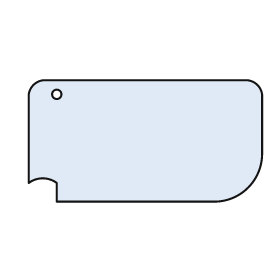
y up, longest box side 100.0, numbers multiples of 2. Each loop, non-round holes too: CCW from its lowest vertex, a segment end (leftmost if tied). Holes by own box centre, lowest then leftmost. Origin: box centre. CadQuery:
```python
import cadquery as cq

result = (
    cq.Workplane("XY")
    .moveTo(-38.0, -26.0)
    .lineTo(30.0, -26.0)
    .threePointArc((44.0, -20.0), (50.0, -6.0))
    .lineTo(50.0, 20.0)
    .threePointArc((48.0, 24.0), (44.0, 26.0))
    .lineTo(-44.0, 26.0)
    .threePointArc((-48.0, 24.0), (-50.0, 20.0))
    .lineTo(-50.0, -18.0)
    .threePointArc((-44.0, -16.0), (-38.0, -18.0))
    .close()
    .moveTo(-38.0, 20.0)
    .circle(2.0)
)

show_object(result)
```